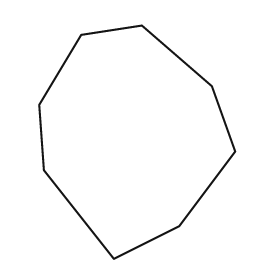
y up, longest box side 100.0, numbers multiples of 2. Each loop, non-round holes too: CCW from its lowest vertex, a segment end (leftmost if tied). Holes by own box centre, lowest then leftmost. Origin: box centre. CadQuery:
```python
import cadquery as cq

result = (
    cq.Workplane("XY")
    .moveTo(-10.0, -50.0)
    .lineTo(18.0, -36.0)
    .lineTo(42.0, -4.0)
    .lineTo(32.0, 24.0)
    .lineTo(2.0, 50.0)
    .lineTo(-24.0, 46.0)
    .lineTo(-42.0, 16.0)
    .lineTo(-40.0, -12.0)
    .close()
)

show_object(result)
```